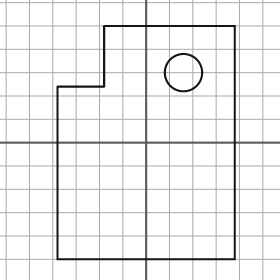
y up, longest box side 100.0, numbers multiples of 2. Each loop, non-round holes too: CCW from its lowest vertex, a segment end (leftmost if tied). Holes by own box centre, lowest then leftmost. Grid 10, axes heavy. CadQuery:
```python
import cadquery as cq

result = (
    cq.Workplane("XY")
    .moveTo(-38.0, -50.0)
    .lineTo(38.0, -50.0)
    .lineTo(38.0, 50.0)
    .lineTo(-18.0, 50.0)
    .lineTo(-18.0, 24.0)
    .lineTo(-38.0, 24.0)
    .close()
    .moveTo(16.0, 30.0)
    .circle(8.0)
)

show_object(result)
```